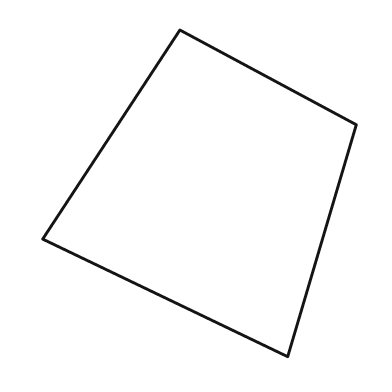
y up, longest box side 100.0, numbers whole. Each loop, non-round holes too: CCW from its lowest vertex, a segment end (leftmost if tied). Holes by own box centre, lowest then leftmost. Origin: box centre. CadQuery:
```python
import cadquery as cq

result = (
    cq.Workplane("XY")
    .moveTo(27.0, -50.0)
    .lineTo(48.0, 21.0)
    .lineTo(-6.0, 50.0)
    .lineTo(-48.0, -14.0)
    .close()
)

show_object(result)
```